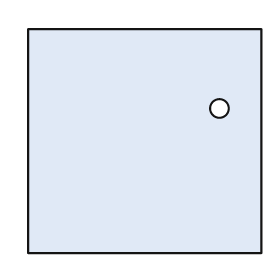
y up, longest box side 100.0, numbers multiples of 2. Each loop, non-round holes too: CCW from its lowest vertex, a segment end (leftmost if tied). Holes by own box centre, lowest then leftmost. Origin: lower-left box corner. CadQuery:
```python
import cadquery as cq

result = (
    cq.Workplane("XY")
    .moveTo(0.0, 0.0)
    .lineTo(100.0, 0.0)
    .lineTo(100.0, 96.0)
    .lineTo(0.0, 96.0)
    .close()
    .moveTo(82.0, 62.0)
    .circle(4.0)
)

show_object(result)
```